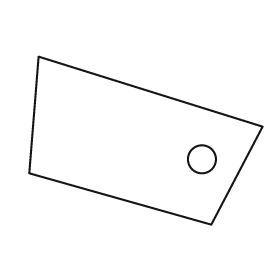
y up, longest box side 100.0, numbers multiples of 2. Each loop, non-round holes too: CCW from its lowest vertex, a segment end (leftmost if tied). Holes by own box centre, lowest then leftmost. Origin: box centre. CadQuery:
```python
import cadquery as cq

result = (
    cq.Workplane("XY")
    .moveTo(28.0, -36.0)
    .lineTo(50.0, 6.0)
    .lineTo(-46.0, 36.0)
    .lineTo(-50.0, -14.0)
    .close()
    .moveTo(24.0, -8.0)
    .circle(6.0)
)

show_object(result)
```